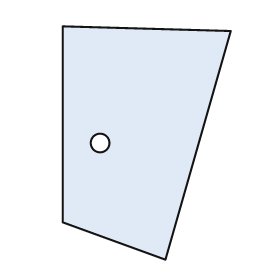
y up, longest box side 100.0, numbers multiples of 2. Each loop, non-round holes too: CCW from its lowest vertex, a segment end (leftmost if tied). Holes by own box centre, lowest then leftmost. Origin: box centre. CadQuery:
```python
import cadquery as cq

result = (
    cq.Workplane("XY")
    .moveTo(8.0, -50.0)
    .lineTo(36.0, 48.0)
    .lineTo(-36.0, 50.0)
    .lineTo(-36.0, -34.0)
    .close()
    .moveTo(-20.0, 0.0)
    .circle(4.0)
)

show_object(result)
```